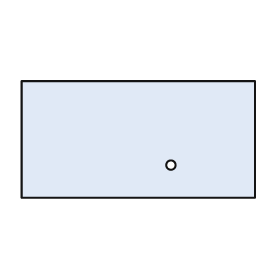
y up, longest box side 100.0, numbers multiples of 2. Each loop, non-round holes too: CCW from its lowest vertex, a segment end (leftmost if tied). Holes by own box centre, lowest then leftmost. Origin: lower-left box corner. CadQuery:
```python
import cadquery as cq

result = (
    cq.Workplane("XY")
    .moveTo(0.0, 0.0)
    .lineTo(100.0, 0.0)
    .lineTo(100.0, 50.0)
    .lineTo(0.0, 50.0)
    .close()
    .moveTo(64.0, 14.0)
    .circle(2.0)
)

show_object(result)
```